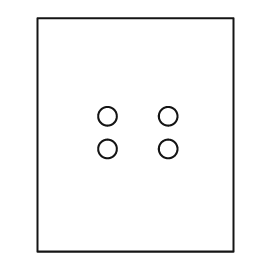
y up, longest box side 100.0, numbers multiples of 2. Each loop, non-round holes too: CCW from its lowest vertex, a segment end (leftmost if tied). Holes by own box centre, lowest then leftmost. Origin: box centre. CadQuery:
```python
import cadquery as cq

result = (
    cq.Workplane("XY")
    .moveTo(-42.0, -50.0)
    .lineTo(42.0, -50.0)
    .lineTo(42.0, 50.0)
    .lineTo(-42.0, 50.0)
    .close()
    .moveTo(-12.0, -6.0)
    .circle(4.0)
    .moveTo(14.0, -6.0)
    .circle(4.0)
    .moveTo(-12.0, 8.0)
    .circle(4.0)
    .moveTo(14.0, 8.0)
    .circle(4.0)
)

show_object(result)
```